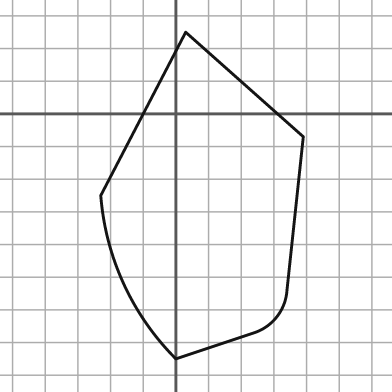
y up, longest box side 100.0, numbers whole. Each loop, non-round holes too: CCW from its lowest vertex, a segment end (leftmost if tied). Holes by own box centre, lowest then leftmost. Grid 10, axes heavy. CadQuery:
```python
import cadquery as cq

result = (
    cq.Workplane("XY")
    .moveTo(0.0, -75.0)
    .lineTo(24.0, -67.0)
    .threePointArc((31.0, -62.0), (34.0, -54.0))
    .lineTo(39.0, -7.0)
    .lineTo(3.0, 25.0)
    .lineTo(-23.0, -25.0)
    .threePointArc((-16.0, -52.0), (0.0, -75.0))
    .close()
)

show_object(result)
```